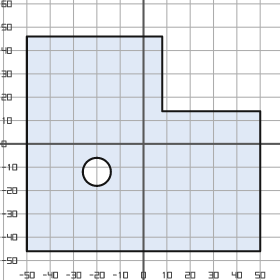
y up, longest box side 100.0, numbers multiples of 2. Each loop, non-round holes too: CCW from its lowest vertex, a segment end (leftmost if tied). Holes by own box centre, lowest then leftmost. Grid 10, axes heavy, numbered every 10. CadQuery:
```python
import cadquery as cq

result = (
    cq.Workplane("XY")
    .moveTo(-50.0, -46.0)
    .lineTo(50.0, -46.0)
    .lineTo(50.0, 14.0)
    .lineTo(8.0, 14.0)
    .lineTo(8.0, 46.0)
    .lineTo(-50.0, 46.0)
    .close()
    .moveTo(-20.0, -12.0)
    .circle(6.0)
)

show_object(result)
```